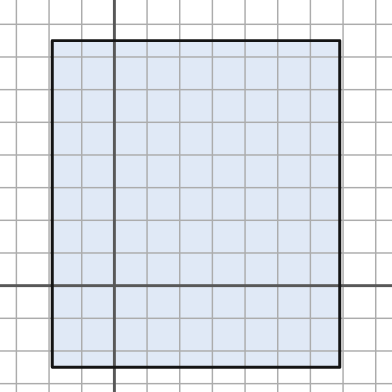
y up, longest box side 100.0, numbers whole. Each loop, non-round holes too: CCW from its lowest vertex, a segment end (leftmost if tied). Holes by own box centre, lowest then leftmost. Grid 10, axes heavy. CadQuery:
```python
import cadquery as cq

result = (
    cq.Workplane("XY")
    .moveTo(-19.0, -25.0)
    .lineTo(69.0, -25.0)
    .lineTo(69.0, 75.0)
    .lineTo(-19.0, 75.0)
    .close()
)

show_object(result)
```